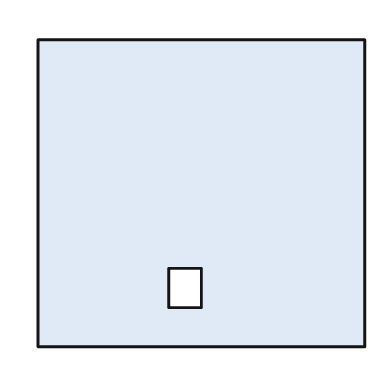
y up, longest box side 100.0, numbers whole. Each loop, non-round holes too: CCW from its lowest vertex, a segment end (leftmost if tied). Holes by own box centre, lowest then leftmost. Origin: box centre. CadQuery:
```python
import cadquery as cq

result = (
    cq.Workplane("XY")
    .moveTo(-50.0, -47.0)
    .lineTo(50.0, -47.0)
    .lineTo(50.0, 47.0)
    .lineTo(-50.0, 47.0)
    .close()
    .moveTo(-10.0, -35.0)
    .lineTo(0.0, -35.0)
    .lineTo(0.0, -23.0)
    .lineTo(-10.0, -23.0)
    .close()
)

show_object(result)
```